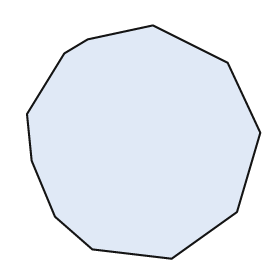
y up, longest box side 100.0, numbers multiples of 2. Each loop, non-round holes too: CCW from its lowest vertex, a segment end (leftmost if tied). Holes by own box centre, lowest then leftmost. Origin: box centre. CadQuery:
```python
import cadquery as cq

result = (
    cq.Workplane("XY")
    .moveTo(12.0, -50.0)
    .lineTo(40.0, -30.0)
    .lineTo(50.0, 4.0)
    .lineTo(36.0, 34.0)
    .lineTo(4.0, 50.0)
    .lineTo(-24.0, 44.0)
    .lineTo(-34.0, 38.0)
    .lineTo(-50.0, 12.0)
    .lineTo(-48.0, -8.0)
    .lineTo(-38.0, -32.0)
    .lineTo(-22.0, -46.0)
    .close()
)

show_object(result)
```